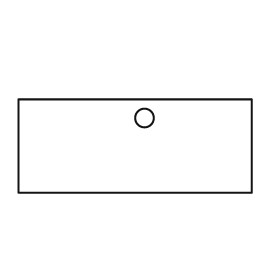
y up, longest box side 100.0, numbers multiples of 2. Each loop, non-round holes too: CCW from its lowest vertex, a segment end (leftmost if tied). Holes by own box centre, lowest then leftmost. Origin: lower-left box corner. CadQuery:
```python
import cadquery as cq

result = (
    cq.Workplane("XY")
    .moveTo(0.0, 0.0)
    .lineTo(100.0, 0.0)
    .lineTo(100.0, 40.0)
    .lineTo(0.0, 40.0)
    .close()
    .moveTo(54.0, 32.0)
    .circle(4.0)
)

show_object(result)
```